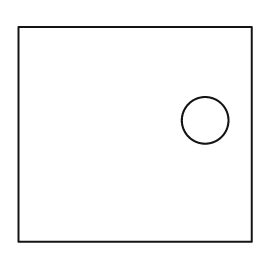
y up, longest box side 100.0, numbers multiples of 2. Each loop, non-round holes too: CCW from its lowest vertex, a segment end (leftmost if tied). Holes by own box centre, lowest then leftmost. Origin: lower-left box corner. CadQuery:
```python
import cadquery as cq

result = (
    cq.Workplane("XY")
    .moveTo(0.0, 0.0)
    .lineTo(100.0, 0.0)
    .lineTo(100.0, 92.0)
    .lineTo(0.0, 92.0)
    .close()
    .moveTo(80.0, 52.0)
    .circle(10.0)
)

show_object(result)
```